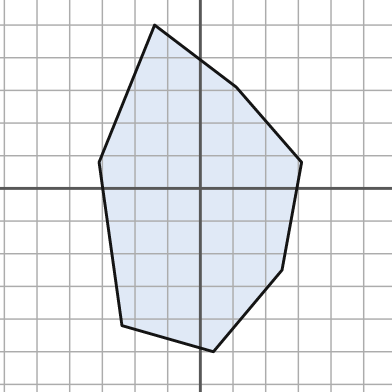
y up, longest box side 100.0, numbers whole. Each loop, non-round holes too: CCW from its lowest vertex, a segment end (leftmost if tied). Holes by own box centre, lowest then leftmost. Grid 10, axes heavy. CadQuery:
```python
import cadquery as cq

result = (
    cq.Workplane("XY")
    .moveTo(4.0, -50.0)
    .lineTo(25.0, -25.0)
    .lineTo(31.0, 8.0)
    .lineTo(11.0, 31.0)
    .lineTo(-14.0, 50.0)
    .lineTo(-31.0, 8.0)
    .lineTo(-24.0, -42.0)
    .close()
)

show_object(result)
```